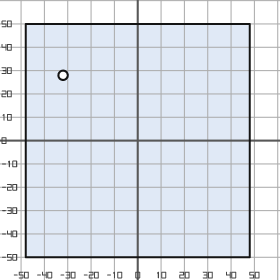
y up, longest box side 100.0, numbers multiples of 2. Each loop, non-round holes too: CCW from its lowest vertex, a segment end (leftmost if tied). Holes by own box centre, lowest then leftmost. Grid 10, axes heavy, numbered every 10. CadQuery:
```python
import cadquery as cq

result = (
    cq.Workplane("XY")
    .moveTo(-48.0, -50.0)
    .lineTo(48.0, -50.0)
    .lineTo(48.0, 50.0)
    .lineTo(-48.0, 50.0)
    .close()
    .moveTo(-32.0, 28.0)
    .circle(2.0)
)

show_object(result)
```